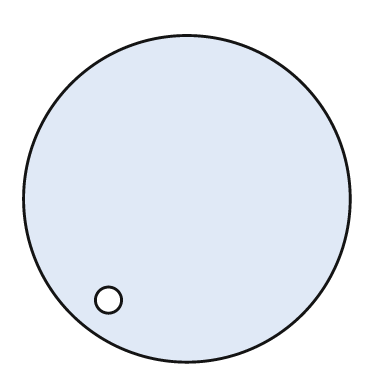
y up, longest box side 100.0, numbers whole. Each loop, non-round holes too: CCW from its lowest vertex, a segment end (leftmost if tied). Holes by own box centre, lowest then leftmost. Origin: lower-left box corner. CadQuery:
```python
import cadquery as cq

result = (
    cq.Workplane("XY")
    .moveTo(50.0, 50.0)
    .circle(50.0)
    .moveTo(26.0, 19.0)
    .circle(4.0)
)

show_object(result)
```